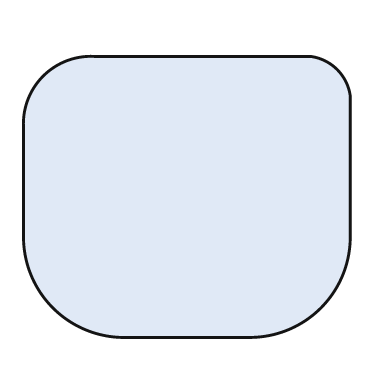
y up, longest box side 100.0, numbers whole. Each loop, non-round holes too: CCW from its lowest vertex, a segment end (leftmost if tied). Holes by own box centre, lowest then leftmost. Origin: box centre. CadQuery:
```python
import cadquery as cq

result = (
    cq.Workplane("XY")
    .moveTo(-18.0, -43.0)
    .lineTo(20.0, -43.0)
    .threePointArc((41.0, -34.0), (50.0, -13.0))
    .lineTo(50.0, 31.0)
    .threePointArc((46.0, 39.0), (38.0, 43.0))
    .lineTo(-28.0, 43.0)
    .threePointArc((-44.0, 37.0), (-50.0, 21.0))
    .lineTo(-50.0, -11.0)
    .threePointArc((-41.0, -34.0), (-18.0, -43.0))
    .close()
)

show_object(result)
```